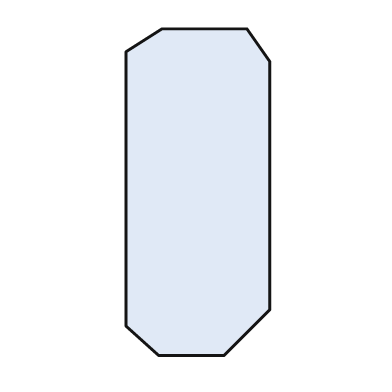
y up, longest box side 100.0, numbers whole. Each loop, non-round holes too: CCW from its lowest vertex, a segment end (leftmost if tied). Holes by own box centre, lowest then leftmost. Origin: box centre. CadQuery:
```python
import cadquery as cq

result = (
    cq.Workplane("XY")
    .moveTo(-12.0, -50.0)
    .lineTo(8.0, -50.0)
    .lineTo(22.0, -36.0)
    .lineTo(22.0, 40.0)
    .lineTo(15.0, 50.0)
    .lineTo(-11.0, 50.0)
    .lineTo(-22.0, 43.0)
    .lineTo(-22.0, -41.0)
    .close()
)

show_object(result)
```